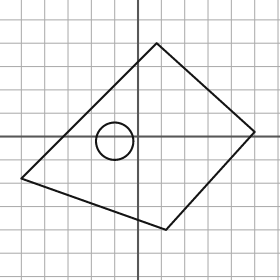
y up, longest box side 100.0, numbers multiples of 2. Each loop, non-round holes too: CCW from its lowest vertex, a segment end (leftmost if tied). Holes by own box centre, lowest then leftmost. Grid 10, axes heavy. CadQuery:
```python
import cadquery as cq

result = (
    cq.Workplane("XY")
    .moveTo(12.0, -40.0)
    .lineTo(50.0, 2.0)
    .lineTo(8.0, 40.0)
    .lineTo(-50.0, -18.0)
    .close()
    .moveTo(-10.0, -2.0)
    .circle(8.0)
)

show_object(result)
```